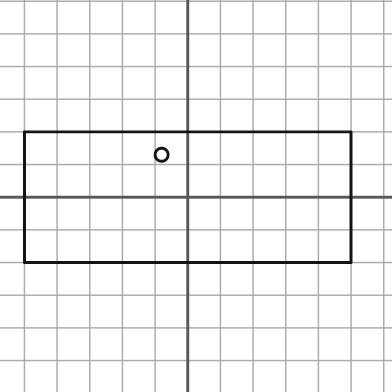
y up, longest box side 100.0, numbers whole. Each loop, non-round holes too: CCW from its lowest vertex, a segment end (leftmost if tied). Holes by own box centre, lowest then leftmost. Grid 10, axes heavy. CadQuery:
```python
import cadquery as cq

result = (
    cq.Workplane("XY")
    .moveTo(-50.0, -20.0)
    .lineTo(50.0, -20.0)
    .lineTo(50.0, 20.0)
    .lineTo(-50.0, 20.0)
    .close()
    .moveTo(-8.0, 13.0)
    .circle(2.0)
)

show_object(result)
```